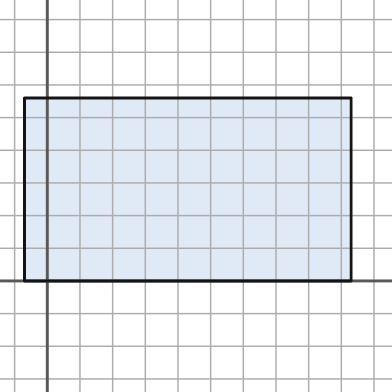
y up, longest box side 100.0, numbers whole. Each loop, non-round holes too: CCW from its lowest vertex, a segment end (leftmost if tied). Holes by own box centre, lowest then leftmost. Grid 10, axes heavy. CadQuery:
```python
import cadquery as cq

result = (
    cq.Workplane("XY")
    .moveTo(-7.0, 0.0)
    .lineTo(93.0, 0.0)
    .lineTo(93.0, 56.0)
    .lineTo(-7.0, 56.0)
    .close()
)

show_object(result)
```